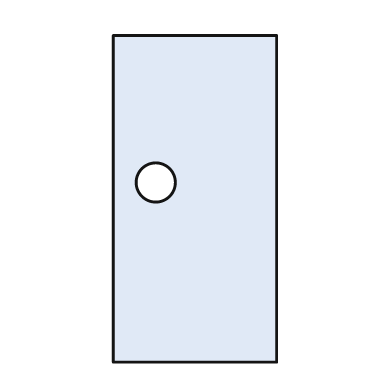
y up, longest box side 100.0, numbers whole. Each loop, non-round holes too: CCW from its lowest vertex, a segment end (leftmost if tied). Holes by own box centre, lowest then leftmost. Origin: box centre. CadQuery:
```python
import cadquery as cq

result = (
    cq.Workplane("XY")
    .moveTo(-25.0, -50.0)
    .lineTo(25.0, -50.0)
    .lineTo(25.0, 50.0)
    .lineTo(-25.0, 50.0)
    .close()
    .moveTo(-12.0, 5.0)
    .circle(6.0)
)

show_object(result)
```